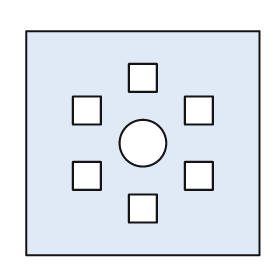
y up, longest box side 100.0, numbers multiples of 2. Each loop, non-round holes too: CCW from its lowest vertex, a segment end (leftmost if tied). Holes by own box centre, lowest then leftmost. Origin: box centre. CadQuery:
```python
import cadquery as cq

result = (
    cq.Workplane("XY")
    .moveTo(-50.0, -48.0)
    .lineTo(50.0, -48.0)
    .lineTo(50.0, 48.0)
    .lineTo(-50.0, 48.0)
    .close()
    .moveTo(-6.0, -34.0)
    .lineTo(6.0, -34.0)
    .lineTo(6.0, -22.0)
    .lineTo(-6.0, -22.0)
    .close()
    .moveTo(-30.0, -20.0)
    .lineTo(-18.0, -20.0)
    .lineTo(-18.0, -8.0)
    .lineTo(-30.0, -8.0)
    .close()
    .moveTo(18.0, -20.0)
    .lineTo(30.0, -20.0)
    .lineTo(30.0, -8.0)
    .lineTo(18.0, -8.0)
    .close()
    .moveTo(0.0, 0.0)
    .circle(10.0)
    .moveTo(-30.0, 8.0)
    .lineTo(-18.0, 8.0)
    .lineTo(-18.0, 20.0)
    .lineTo(-30.0, 20.0)
    .close()
    .moveTo(18.0, 8.0)
    .lineTo(30.0, 8.0)
    .lineTo(30.0, 20.0)
    .lineTo(18.0, 20.0)
    .close()
    .moveTo(-6.0, 22.0)
    .lineTo(6.0, 22.0)
    .lineTo(6.0, 34.0)
    .lineTo(-6.0, 34.0)
    .close()
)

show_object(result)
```